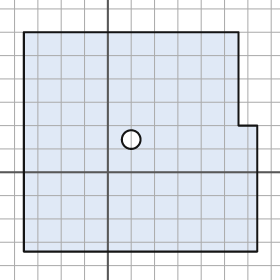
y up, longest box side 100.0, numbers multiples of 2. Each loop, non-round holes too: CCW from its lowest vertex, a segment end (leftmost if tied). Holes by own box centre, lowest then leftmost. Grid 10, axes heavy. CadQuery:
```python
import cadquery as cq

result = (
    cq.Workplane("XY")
    .moveTo(-36.0, -34.0)
    .lineTo(64.0, -34.0)
    .lineTo(64.0, 20.0)
    .lineTo(56.0, 20.0)
    .lineTo(56.0, 60.0)
    .lineTo(-36.0, 60.0)
    .close()
    .moveTo(10.0, 14.0)
    .circle(4.0)
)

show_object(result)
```